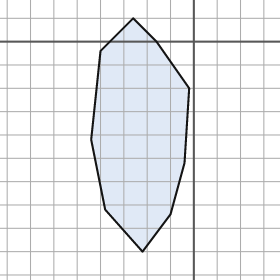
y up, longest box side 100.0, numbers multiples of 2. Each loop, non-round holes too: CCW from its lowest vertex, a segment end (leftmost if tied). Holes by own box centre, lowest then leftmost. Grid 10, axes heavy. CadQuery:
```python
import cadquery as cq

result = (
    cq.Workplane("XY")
    .moveTo(-22.0, -90.0)
    .lineTo(-10.0, -74.0)
    .lineTo(-4.0, -52.0)
    .lineTo(-2.0, -20.0)
    .lineTo(-16.0, 0.0)
    .lineTo(-26.0, 10.0)
    .lineTo(-40.0, -4.0)
    .lineTo(-44.0, -42.0)
    .lineTo(-38.0, -72.0)
    .close()
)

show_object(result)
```